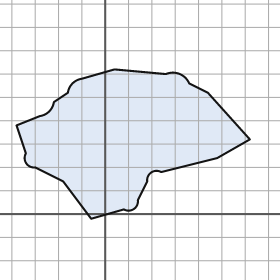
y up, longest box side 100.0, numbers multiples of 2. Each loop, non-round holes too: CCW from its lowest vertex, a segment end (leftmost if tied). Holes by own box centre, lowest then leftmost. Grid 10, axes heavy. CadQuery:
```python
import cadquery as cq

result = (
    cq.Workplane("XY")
    .moveTo(-6.0, -2.0)
    .lineTo(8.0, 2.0)
    .threePointArc((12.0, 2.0), (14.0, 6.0))
    .lineTo(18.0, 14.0)
    .threePointArc((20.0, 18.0), (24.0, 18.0))
    .lineTo(48.0, 24.0)
    .lineTo(62.0, 32.0)
    .lineTo(44.0, 52.0)
    .lineTo(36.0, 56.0)
    .threePointArc((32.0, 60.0), (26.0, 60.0))
    .lineTo(4.0, 62.0)
    .lineTo(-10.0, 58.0)
    .threePointArc((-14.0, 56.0), (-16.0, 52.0))
    .lineTo(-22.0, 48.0)
    .threePointArc((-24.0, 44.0), (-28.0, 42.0))
    .lineTo(-38.0, 38.0)
    .lineTo(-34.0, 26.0)
    .threePointArc((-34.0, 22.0), (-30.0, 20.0))
    .lineTo(-18.0, 14.0)
    .close()
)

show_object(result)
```